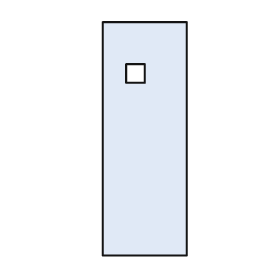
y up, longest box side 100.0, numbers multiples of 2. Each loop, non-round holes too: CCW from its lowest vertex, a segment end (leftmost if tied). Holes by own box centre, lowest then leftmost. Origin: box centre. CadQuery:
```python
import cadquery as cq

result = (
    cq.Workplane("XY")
    .moveTo(-18.0, -50.0)
    .lineTo(18.0, -50.0)
    .lineTo(18.0, 50.0)
    .lineTo(-18.0, 50.0)
    .close()
    .moveTo(-8.0, 24.0)
    .lineTo(0.0, 24.0)
    .lineTo(0.0, 32.0)
    .lineTo(-8.0, 32.0)
    .close()
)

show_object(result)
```